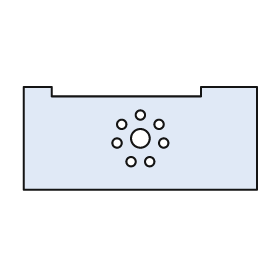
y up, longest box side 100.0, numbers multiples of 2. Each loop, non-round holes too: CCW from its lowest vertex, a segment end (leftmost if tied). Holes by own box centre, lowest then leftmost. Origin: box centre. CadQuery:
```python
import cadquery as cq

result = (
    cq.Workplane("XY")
    .moveTo(-50.0, -22.0)
    .lineTo(50.0, -22.0)
    .lineTo(50.0, 22.0)
    .lineTo(26.0, 22.0)
    .lineTo(26.0, 18.0)
    .lineTo(-38.0, 18.0)
    .lineTo(-38.0, 22.0)
    .lineTo(-50.0, 22.0)
    .close()
    .moveTo(-4.0, -10.0)
    .circle(2.0)
    .moveTo(4.0, -10.0)
    .circle(2.0)
    .moveTo(-10.0, -2.0)
    .circle(2.0)
    .moveTo(10.0, -2.0)
    .circle(2.0)
    .moveTo(0.0, 0.0)
    .circle(4.0)
    .moveTo(-8.0, 6.0)
    .circle(2.0)
    .moveTo(8.0, 6.0)
    .circle(2.0)
    .moveTo(0.0, 10.0)
    .circle(2.0)
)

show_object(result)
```